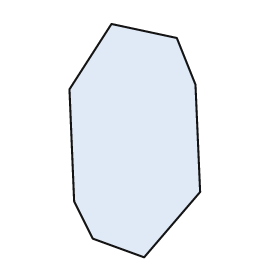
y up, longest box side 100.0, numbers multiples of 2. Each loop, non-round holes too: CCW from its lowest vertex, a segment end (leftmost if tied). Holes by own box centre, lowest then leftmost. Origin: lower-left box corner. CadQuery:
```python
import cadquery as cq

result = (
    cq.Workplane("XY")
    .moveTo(32.0, 0.0)
    .lineTo(56.0, 28.0)
    .lineTo(54.0, 74.0)
    .lineTo(46.0, 94.0)
    .lineTo(18.0, 100.0)
    .lineTo(0.0, 72.0)
    .lineTo(2.0, 24.0)
    .lineTo(10.0, 8.0)
    .close()
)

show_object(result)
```